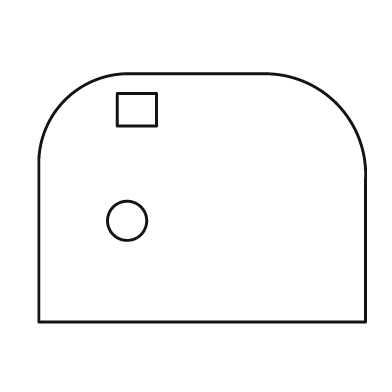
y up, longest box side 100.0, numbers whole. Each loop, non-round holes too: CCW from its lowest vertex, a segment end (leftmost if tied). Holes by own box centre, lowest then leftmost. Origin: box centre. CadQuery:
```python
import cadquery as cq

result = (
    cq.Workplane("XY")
    .moveTo(-50.0, -38.0)
    .lineTo(50.0, -38.0)
    .lineTo(50.0, 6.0)
    .threePointArc((41.0, 29.0), (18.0, 38.0))
    .lineTo(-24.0, 38.0)
    .threePointArc((-42.0, 30.0), (-50.0, 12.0))
    .close()
    .moveTo(-23.0, -7.0)
    .circle(6.0)
    .moveTo(-26.0, 22.0)
    .lineTo(-14.0, 22.0)
    .lineTo(-14.0, 32.0)
    .lineTo(-26.0, 32.0)
    .close()
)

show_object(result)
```